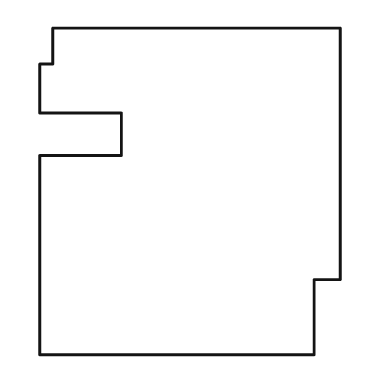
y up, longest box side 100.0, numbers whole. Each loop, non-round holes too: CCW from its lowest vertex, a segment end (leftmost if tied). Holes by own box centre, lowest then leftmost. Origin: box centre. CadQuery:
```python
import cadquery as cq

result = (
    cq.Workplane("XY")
    .moveTo(-46.0, -50.0)
    .lineTo(38.0, -50.0)
    .lineTo(38.0, -27.0)
    .lineTo(46.0, -27.0)
    .lineTo(46.0, 50.0)
    .lineTo(-42.0, 50.0)
    .lineTo(-42.0, 39.0)
    .lineTo(-46.0, 39.0)
    .lineTo(-46.0, 24.0)
    .lineTo(-21.0, 24.0)
    .lineTo(-21.0, 11.0)
    .lineTo(-46.0, 11.0)
    .close()
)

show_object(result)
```